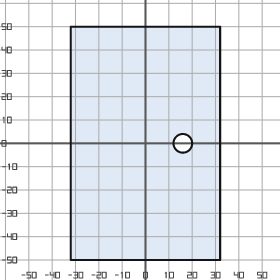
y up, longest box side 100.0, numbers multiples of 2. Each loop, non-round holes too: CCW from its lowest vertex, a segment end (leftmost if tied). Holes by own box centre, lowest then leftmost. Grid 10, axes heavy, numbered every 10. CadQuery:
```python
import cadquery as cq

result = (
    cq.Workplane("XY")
    .moveTo(-32.0, -50.0)
    .lineTo(32.0, -50.0)
    .lineTo(32.0, 50.0)
    .lineTo(-32.0, 50.0)
    .close()
    .moveTo(16.0, 0.0)
    .circle(4.0)
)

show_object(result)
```